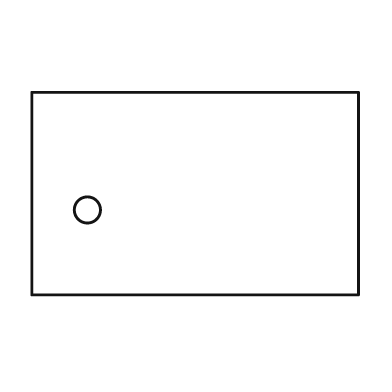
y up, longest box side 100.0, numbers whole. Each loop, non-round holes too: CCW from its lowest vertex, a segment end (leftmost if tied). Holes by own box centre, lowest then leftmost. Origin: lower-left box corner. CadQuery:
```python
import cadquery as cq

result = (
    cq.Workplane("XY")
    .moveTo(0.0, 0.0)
    .lineTo(100.0, 0.0)
    .lineTo(100.0, 62.0)
    .lineTo(0.0, 62.0)
    .close()
    .moveTo(17.0, 26.0)
    .circle(4.0)
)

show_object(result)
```